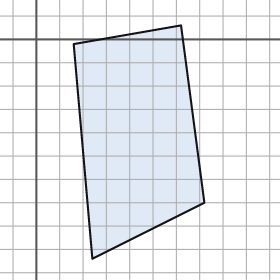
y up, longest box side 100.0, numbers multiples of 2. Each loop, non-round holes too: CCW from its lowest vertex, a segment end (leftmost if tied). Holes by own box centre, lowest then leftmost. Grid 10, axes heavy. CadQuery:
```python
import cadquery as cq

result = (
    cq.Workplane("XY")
    .moveTo(24.0, -94.0)
    .lineTo(72.0, -70.0)
    .lineTo(62.0, 6.0)
    .lineTo(16.0, -2.0)
    .close()
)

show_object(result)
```